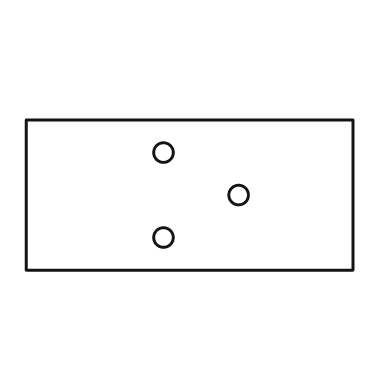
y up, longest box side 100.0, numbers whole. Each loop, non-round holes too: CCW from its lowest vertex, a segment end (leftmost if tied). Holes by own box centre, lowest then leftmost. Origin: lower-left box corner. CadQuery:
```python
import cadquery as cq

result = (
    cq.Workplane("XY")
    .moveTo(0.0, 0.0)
    .lineTo(100.0, 0.0)
    .lineTo(100.0, 46.0)
    .lineTo(0.0, 46.0)
    .close()
    .moveTo(42.0, 10.0)
    .circle(3.0)
    .moveTo(65.0, 23.0)
    .circle(3.0)
    .moveTo(42.0, 36.0)
    .circle(3.0)
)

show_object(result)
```